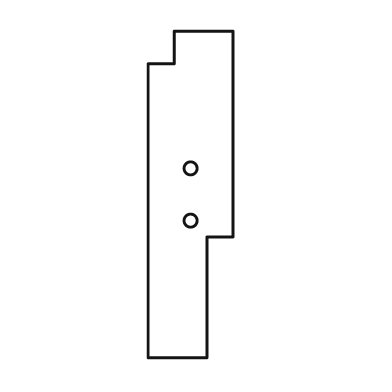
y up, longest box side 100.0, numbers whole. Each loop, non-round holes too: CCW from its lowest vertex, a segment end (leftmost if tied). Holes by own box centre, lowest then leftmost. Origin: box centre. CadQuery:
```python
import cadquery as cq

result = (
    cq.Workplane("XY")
    .moveTo(-13.0, -50.0)
    .lineTo(5.0, -50.0)
    .lineTo(5.0, -13.0)
    .lineTo(13.0, -13.0)
    .lineTo(13.0, 50.0)
    .lineTo(-5.0, 50.0)
    .lineTo(-5.0, 40.0)
    .lineTo(-13.0, 40.0)
    .close()
    .moveTo(0.0, -8.0)
    .circle(2.0)
    .moveTo(0.0, 8.0)
    .circle(2.0)
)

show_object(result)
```